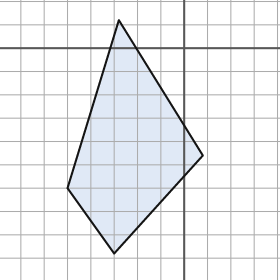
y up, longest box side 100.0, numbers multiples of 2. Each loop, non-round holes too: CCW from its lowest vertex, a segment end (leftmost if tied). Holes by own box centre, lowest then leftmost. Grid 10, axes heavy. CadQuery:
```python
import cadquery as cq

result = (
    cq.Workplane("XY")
    .moveTo(-30.0, -88.0)
    .lineTo(8.0, -46.0)
    .lineTo(-28.0, 12.0)
    .lineTo(-50.0, -60.0)
    .close()
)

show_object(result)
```